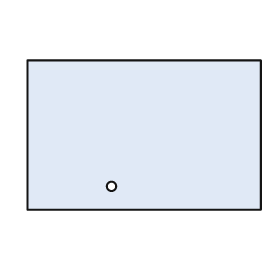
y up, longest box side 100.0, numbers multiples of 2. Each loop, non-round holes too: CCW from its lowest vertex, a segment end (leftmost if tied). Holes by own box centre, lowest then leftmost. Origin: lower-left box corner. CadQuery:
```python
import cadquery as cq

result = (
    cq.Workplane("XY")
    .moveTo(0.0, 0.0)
    .lineTo(100.0, 0.0)
    .lineTo(100.0, 64.0)
    .lineTo(0.0, 64.0)
    .close()
    .moveTo(36.0, 10.0)
    .circle(2.0)
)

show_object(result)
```